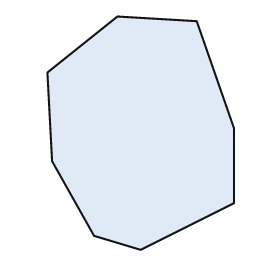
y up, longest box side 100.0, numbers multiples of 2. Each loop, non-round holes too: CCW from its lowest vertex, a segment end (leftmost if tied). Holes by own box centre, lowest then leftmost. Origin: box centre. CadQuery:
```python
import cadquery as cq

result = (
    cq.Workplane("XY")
    .moveTo(0.0, -50.0)
    .lineTo(40.0, -30.0)
    .lineTo(40.0, 2.0)
    .lineTo(24.0, 48.0)
    .lineTo(-10.0, 50.0)
    .lineTo(-40.0, 26.0)
    .lineTo(-38.0, -12.0)
    .lineTo(-20.0, -44.0)
    .close()
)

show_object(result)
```